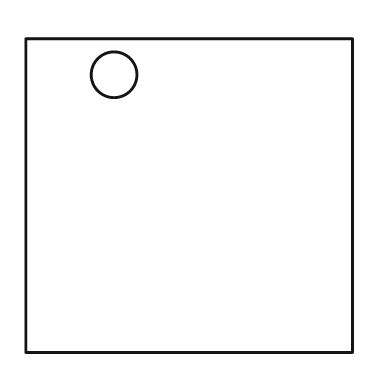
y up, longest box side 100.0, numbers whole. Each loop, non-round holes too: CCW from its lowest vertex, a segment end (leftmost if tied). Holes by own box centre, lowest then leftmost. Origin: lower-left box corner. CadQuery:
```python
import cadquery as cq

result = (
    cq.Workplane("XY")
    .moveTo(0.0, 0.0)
    .lineTo(100.0, 0.0)
    .lineTo(100.0, 96.0)
    .lineTo(0.0, 96.0)
    .close()
    .moveTo(27.0, 85.0)
    .circle(7.0)
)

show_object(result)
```